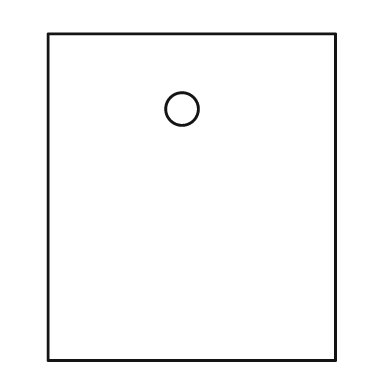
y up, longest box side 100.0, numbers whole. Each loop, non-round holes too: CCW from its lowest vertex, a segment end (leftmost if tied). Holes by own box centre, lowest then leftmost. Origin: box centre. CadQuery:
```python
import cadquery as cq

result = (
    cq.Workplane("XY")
    .moveTo(-44.0, -50.0)
    .lineTo(44.0, -50.0)
    .lineTo(44.0, 50.0)
    .lineTo(-44.0, 50.0)
    .close()
    .moveTo(-3.0, 27.0)
    .circle(5.0)
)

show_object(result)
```